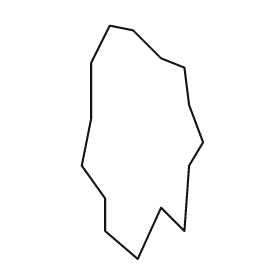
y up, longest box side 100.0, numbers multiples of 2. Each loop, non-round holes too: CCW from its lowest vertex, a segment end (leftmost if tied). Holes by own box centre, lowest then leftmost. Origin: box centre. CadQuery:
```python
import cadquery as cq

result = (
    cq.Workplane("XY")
    .moveTo(-2.0, -50.0)
    .lineTo(8.0, -28.0)
    .lineTo(18.0, -38.0)
    .lineTo(20.0, -10.0)
    .lineTo(26.0, 0.0)
    .lineTo(20.0, 16.0)
    .lineTo(18.0, 32.0)
    .lineTo(8.0, 36.0)
    .lineTo(-4.0, 48.0)
    .lineTo(-14.0, 50.0)
    .lineTo(-22.0, 34.0)
    .lineTo(-22.0, 10.0)
    .lineTo(-26.0, -10.0)
    .lineTo(-16.0, -24.0)
    .lineTo(-16.0, -38.0)
    .close()
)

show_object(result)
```